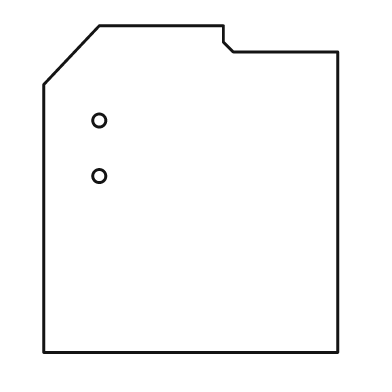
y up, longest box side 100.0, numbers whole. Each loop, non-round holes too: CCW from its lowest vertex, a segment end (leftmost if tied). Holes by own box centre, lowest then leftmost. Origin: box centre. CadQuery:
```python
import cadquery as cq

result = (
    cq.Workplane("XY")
    .moveTo(-45.0, -50.0)
    .lineTo(45.0, -50.0)
    .lineTo(45.0, 42.0)
    .lineTo(13.0, 42.0)
    .lineTo(10.0, 45.0)
    .lineTo(10.0, 50.0)
    .lineTo(-28.0, 50.0)
    .lineTo(-45.0, 32.0)
    .close()
    .moveTo(-28.0, 4.0)
    .circle(2.0)
    .moveTo(-28.0, 21.0)
    .circle(2.0)
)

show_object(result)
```